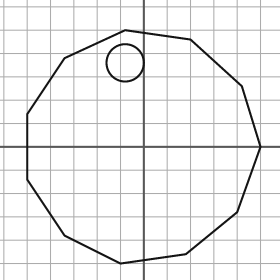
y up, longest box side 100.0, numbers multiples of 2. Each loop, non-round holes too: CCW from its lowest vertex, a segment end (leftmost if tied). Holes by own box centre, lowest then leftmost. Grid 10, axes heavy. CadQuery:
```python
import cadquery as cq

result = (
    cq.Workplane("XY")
    .moveTo(-10.0, -50.0)
    .lineTo(18.0, -46.0)
    .lineTo(40.0, -28.0)
    .lineTo(50.0, 0.0)
    .lineTo(42.0, 26.0)
    .lineTo(20.0, 46.0)
    .lineTo(-8.0, 50.0)
    .lineTo(-34.0, 38.0)
    .lineTo(-50.0, 14.0)
    .lineTo(-50.0, -14.0)
    .lineTo(-34.0, -38.0)
    .close()
    .moveTo(-8.0, 36.0)
    .circle(8.0)
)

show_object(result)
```